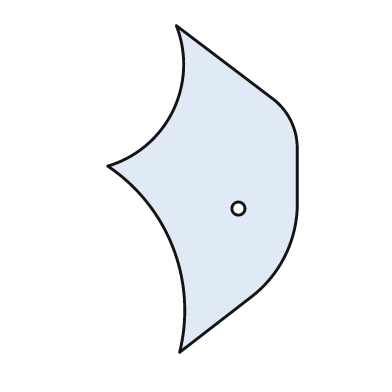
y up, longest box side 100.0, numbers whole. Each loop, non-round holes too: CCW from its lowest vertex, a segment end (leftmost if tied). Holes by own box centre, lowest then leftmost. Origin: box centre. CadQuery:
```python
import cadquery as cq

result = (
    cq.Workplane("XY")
    .moveTo(-7.0, -50.0)
    .lineTo(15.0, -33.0)
    .threePointArc((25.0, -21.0), (29.0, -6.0))
    .lineTo(29.0, 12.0)
    .threePointArc((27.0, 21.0), (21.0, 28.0))
    .lineTo(-8.0, 50.0)
    .threePointArc((-9.0, 24.0), (-29.0, 7.0))
    .threePointArc((-9.0, -18.0), (-7.0, -50.0))
    .close()
    .moveTo(11.0, -6.0)
    .circle(2.0)
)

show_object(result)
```